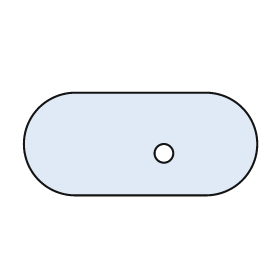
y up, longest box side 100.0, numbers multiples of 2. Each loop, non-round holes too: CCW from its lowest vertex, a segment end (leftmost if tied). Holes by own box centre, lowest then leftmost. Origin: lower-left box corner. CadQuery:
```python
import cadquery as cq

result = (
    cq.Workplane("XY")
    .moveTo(22.0, 0.0)
    .lineTo(78.0, 0.0)
    .threePointArc((100.0, 22.0), (78.0, 44.0))
    .lineTo(22.0, 44.0)
    .threePointArc((0.0, 22.0), (22.0, 0.0))
    .close()
    .moveTo(60.0, 18.0)
    .circle(4.0)
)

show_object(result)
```